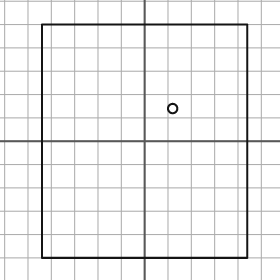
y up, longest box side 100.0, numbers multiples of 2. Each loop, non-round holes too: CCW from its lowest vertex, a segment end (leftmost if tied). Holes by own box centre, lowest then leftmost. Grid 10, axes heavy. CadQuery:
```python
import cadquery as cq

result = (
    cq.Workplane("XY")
    .moveTo(-44.0, -50.0)
    .lineTo(44.0, -50.0)
    .lineTo(44.0, 50.0)
    .lineTo(-44.0, 50.0)
    .close()
    .moveTo(12.0, 14.0)
    .circle(2.0)
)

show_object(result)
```